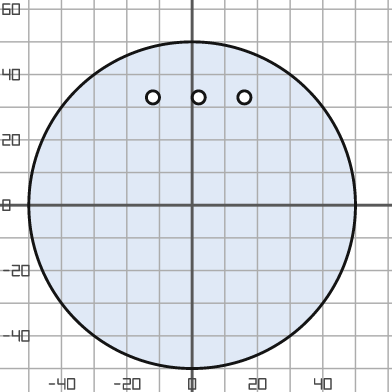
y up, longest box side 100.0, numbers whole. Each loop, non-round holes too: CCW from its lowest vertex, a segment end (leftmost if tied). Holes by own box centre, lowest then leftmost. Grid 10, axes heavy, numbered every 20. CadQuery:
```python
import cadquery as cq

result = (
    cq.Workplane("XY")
    .moveTo(0.0, 0.0)
    .circle(50.0)
    .moveTo(-12.0, 33.0)
    .circle(2.0)
    .moveTo(2.0, 33.0)
    .circle(2.0)
    .moveTo(16.0, 33.0)
    .circle(2.0)
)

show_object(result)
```